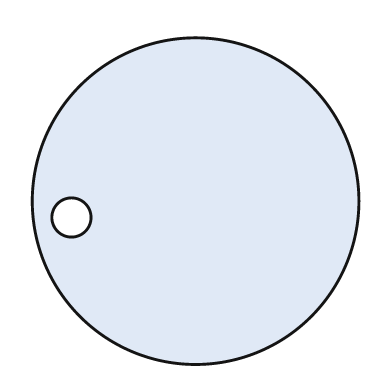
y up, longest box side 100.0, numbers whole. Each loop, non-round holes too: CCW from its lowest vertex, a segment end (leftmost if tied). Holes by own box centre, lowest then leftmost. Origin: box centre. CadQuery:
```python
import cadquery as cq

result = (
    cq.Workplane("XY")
    .moveTo(0.0, 0.0)
    .circle(50.0)
    .moveTo(-38.0, -5.0)
    .circle(6.0)
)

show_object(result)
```